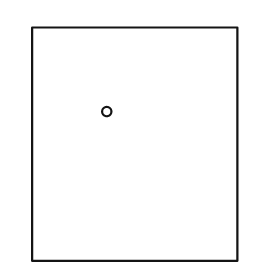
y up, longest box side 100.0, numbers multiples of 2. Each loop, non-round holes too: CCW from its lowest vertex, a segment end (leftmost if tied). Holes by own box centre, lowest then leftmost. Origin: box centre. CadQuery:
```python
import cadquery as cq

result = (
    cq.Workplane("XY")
    .moveTo(-44.0, -50.0)
    .lineTo(44.0, -50.0)
    .lineTo(44.0, 50.0)
    .lineTo(-44.0, 50.0)
    .close()
    .moveTo(-12.0, 14.0)
    .circle(2.0)
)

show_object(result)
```